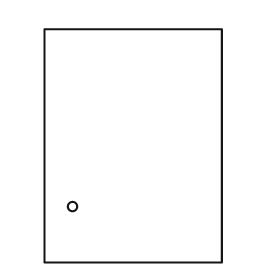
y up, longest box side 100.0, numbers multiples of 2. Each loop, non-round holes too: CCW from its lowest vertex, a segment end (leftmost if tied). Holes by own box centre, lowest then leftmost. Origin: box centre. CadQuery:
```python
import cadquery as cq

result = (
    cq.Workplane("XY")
    .moveTo(-38.0, -50.0)
    .lineTo(38.0, -50.0)
    .lineTo(38.0, 50.0)
    .lineTo(-38.0, 50.0)
    .close()
    .moveTo(-26.0, -26.0)
    .circle(2.0)
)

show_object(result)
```